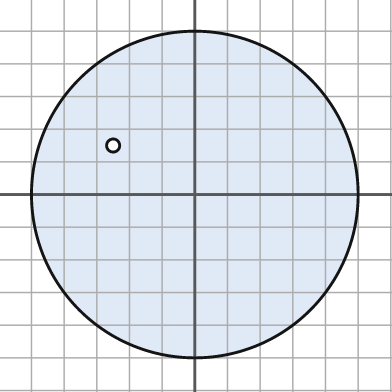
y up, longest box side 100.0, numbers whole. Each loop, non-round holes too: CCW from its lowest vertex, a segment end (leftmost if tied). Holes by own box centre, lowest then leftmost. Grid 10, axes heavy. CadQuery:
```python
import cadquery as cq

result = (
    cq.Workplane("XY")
    .moveTo(0.0, 0.0)
    .circle(50.0)
    .moveTo(-25.0, 15.0)
    .circle(2.0)
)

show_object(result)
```